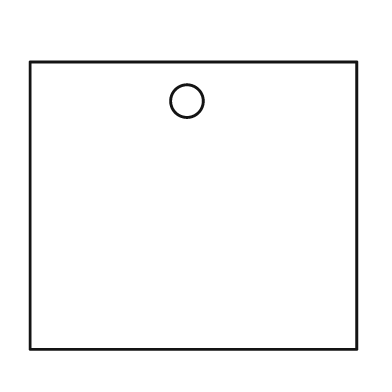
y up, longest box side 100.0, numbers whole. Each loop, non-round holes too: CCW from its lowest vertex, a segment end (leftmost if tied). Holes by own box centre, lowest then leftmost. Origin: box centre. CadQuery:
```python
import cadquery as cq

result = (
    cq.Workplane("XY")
    .moveTo(-50.0, -44.0)
    .lineTo(50.0, -44.0)
    .lineTo(50.0, 44.0)
    .lineTo(-50.0, 44.0)
    .close()
    .moveTo(-2.0, 32.0)
    .circle(5.0)
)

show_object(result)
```